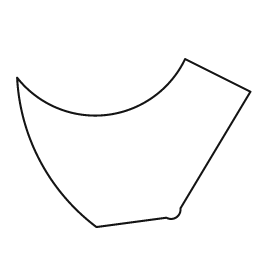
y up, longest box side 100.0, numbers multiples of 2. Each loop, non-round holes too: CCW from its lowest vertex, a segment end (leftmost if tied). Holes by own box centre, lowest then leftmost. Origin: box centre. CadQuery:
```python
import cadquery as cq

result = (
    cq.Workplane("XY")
    .moveTo(-16.0, -36.0)
    .lineTo(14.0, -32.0)
    .threePointArc((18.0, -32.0), (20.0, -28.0))
    .lineTo(50.0, 22.0)
    .lineTo(22.0, 36.0)
    .threePointArc((-12.0, 12.0), (-50.0, 28.0))
    .threePointArc((-40.0, -8.0), (-16.0, -36.0))
    .close()
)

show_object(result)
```